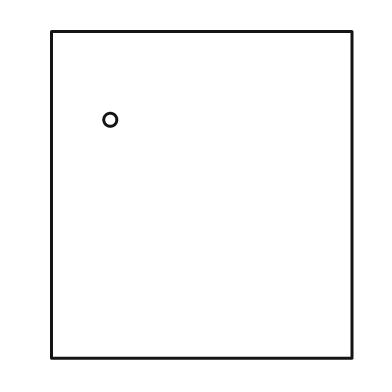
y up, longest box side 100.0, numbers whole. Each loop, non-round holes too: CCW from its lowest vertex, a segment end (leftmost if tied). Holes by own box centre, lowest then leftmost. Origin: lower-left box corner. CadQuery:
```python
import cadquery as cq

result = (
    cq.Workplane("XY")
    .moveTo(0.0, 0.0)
    .lineTo(92.0, 0.0)
    .lineTo(92.0, 100.0)
    .lineTo(0.0, 100.0)
    .close()
    .moveTo(18.0, 73.0)
    .circle(2.0)
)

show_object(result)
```